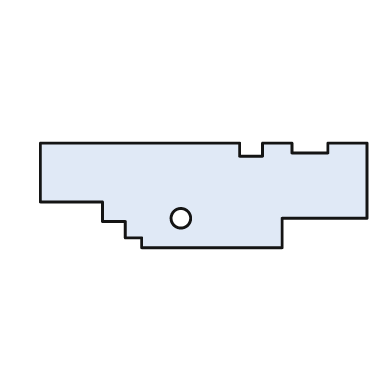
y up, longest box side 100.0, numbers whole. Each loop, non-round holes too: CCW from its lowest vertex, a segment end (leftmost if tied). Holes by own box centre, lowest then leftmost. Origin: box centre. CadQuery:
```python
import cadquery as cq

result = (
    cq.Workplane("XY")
    .moveTo(-19.0, -16.0)
    .lineTo(24.0, -16.0)
    .lineTo(24.0, -7.0)
    .lineTo(50.0, -7.0)
    .lineTo(50.0, 16.0)
    .lineTo(38.0, 16.0)
    .lineTo(38.0, 13.0)
    .lineTo(27.0, 13.0)
    .lineTo(27.0, 16.0)
    .lineTo(18.0, 16.0)
    .lineTo(18.0, 12.0)
    .lineTo(11.0, 12.0)
    .lineTo(11.0, 16.0)
    .lineTo(-50.0, 16.0)
    .lineTo(-50.0, -2.0)
    .lineTo(-31.0, -2.0)
    .lineTo(-31.0, -8.0)
    .lineTo(-24.0, -8.0)
    .lineTo(-24.0, -13.0)
    .lineTo(-19.0, -13.0)
    .close()
    .moveTo(-7.0, -7.0)
    .circle(3.0)
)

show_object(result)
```